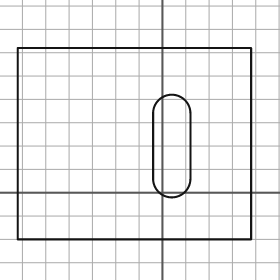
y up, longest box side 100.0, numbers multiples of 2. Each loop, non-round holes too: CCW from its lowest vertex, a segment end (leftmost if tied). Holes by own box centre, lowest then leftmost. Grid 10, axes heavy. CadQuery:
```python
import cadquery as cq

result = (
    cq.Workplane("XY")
    .moveTo(-62.0, -20.0)
    .lineTo(38.0, -20.0)
    .lineTo(38.0, 62.0)
    .lineTo(-62.0, 62.0)
    .close()
    .moveTo(-4.0, 6.0)
    .threePointArc((4.0, -2.0), (12.0, 6.0))
    .lineTo(12.0, 34.0)
    .threePointArc((4.0, 42.0), (-4.0, 34.0))
    .close()
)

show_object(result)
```